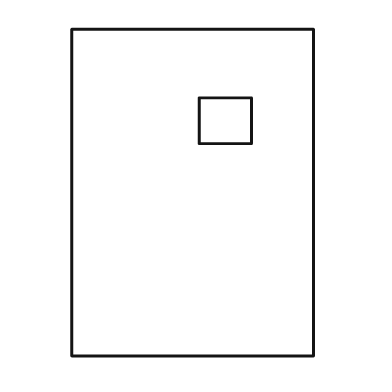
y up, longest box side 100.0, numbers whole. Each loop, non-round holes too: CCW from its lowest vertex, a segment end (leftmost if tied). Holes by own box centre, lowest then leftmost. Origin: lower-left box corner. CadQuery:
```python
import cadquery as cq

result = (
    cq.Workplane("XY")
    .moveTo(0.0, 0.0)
    .lineTo(74.0, 0.0)
    .lineTo(74.0, 100.0)
    .lineTo(0.0, 100.0)
    .close()
    .moveTo(39.0, 65.0)
    .lineTo(55.0, 65.0)
    .lineTo(55.0, 79.0)
    .lineTo(39.0, 79.0)
    .close()
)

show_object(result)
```